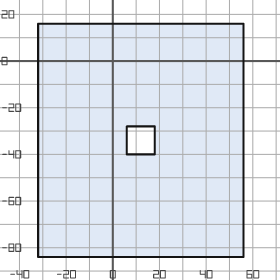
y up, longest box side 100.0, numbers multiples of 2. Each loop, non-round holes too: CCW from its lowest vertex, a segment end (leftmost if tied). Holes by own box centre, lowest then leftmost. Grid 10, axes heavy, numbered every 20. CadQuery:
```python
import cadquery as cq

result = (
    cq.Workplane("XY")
    .moveTo(-32.0, -84.0)
    .lineTo(56.0, -84.0)
    .lineTo(56.0, 16.0)
    .lineTo(-32.0, 16.0)
    .close()
    .moveTo(6.0, -40.0)
    .lineTo(18.0, -40.0)
    .lineTo(18.0, -28.0)
    .lineTo(6.0, -28.0)
    .close()
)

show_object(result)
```